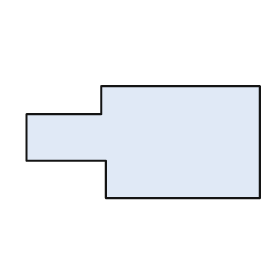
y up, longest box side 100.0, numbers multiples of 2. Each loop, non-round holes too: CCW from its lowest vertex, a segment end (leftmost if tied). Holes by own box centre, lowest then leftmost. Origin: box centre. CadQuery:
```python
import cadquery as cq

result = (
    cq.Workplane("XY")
    .moveTo(-16.0, -24.0)
    .lineTo(50.0, -24.0)
    .lineTo(50.0, 24.0)
    .lineTo(-18.0, 24.0)
    .lineTo(-18.0, 12.0)
    .lineTo(-50.0, 12.0)
    .lineTo(-50.0, -8.0)
    .lineTo(-16.0, -8.0)
    .close()
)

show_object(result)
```